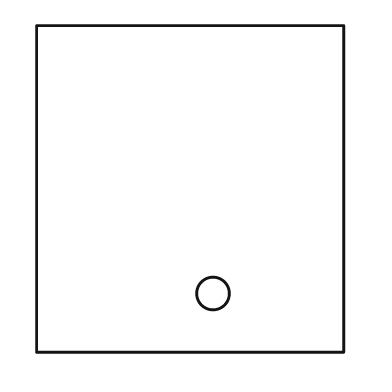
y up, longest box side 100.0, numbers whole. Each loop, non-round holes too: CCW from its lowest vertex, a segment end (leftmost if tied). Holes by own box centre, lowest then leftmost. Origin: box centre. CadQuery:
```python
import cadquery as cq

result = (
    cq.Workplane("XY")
    .moveTo(-47.0, -50.0)
    .lineTo(47.0, -50.0)
    .lineTo(47.0, 50.0)
    .lineTo(-47.0, 50.0)
    .close()
    .moveTo(7.0, -32.0)
    .circle(5.0)
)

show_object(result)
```